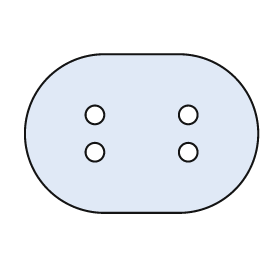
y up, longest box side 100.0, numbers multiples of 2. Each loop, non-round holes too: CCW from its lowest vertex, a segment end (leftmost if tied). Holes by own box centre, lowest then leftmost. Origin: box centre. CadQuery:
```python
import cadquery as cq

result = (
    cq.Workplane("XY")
    .moveTo(-16.0, -34.0)
    .lineTo(16.0, -34.0)
    .threePointArc((50.0, 0.0), (16.0, 34.0))
    .lineTo(-16.0, 34.0)
    .threePointArc((-50.0, 0.0), (-16.0, -34.0))
    .close()
    .moveTo(-20.0, -8.0)
    .circle(4.0)
    .moveTo(20.0, -8.0)
    .circle(4.0)
    .moveTo(-20.0, 8.0)
    .circle(4.0)
    .moveTo(20.0, 8.0)
    .circle(4.0)
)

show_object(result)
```